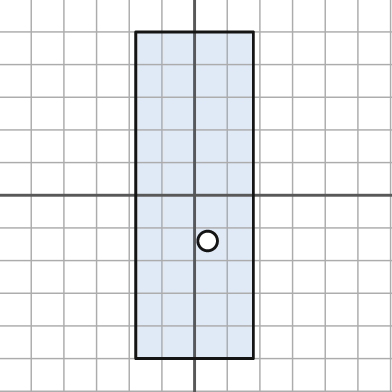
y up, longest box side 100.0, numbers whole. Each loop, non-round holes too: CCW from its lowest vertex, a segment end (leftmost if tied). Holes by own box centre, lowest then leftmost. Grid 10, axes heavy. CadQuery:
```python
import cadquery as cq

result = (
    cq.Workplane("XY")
    .moveTo(-18.0, -50.0)
    .lineTo(18.0, -50.0)
    .lineTo(18.0, 50.0)
    .lineTo(-18.0, 50.0)
    .close()
    .moveTo(4.0, -14.0)
    .circle(3.0)
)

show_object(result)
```